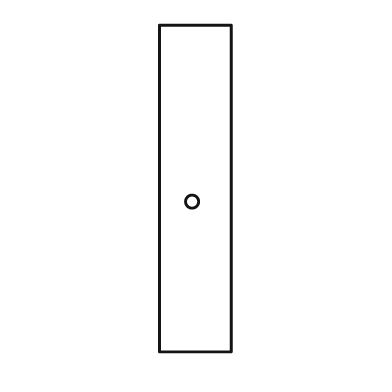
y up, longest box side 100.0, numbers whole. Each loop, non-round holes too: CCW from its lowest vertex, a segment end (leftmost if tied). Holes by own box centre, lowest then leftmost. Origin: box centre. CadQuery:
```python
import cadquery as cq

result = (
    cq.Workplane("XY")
    .moveTo(-11.0, -50.0)
    .lineTo(11.0, -50.0)
    .lineTo(11.0, 50.0)
    .lineTo(-11.0, 50.0)
    .close()
    .moveTo(-1.0, -4.0)
    .circle(2.0)
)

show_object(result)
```